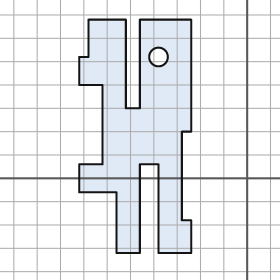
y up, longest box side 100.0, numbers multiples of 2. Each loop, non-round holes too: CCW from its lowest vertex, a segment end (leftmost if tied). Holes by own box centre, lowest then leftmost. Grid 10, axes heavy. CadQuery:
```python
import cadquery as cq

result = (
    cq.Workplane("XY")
    .moveTo(-56.0, -32.0)
    .lineTo(-46.0, -32.0)
    .lineTo(-46.0, 6.0)
    .lineTo(-38.0, 6.0)
    .lineTo(-38.0, -32.0)
    .lineTo(-24.0, -32.0)
    .lineTo(-24.0, -18.0)
    .lineTo(-28.0, -18.0)
    .lineTo(-28.0, 20.0)
    .lineTo(-24.0, 20.0)
    .lineTo(-24.0, 68.0)
    .lineTo(-46.0, 68.0)
    .lineTo(-46.0, 30.0)
    .lineTo(-52.0, 30.0)
    .lineTo(-52.0, 68.0)
    .lineTo(-68.0, 68.0)
    .lineTo(-68.0, 52.0)
    .lineTo(-72.0, 52.0)
    .lineTo(-72.0, 40.0)
    .lineTo(-62.0, 40.0)
    .lineTo(-62.0, 6.0)
    .lineTo(-72.0, 6.0)
    .lineTo(-72.0, -6.0)
    .lineTo(-56.0, -6.0)
    .close()
    .moveTo(-38.0, 52.0)
    .circle(4.0)
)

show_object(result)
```